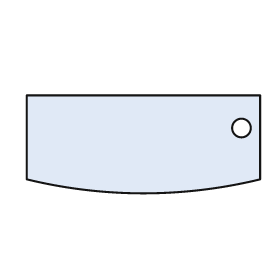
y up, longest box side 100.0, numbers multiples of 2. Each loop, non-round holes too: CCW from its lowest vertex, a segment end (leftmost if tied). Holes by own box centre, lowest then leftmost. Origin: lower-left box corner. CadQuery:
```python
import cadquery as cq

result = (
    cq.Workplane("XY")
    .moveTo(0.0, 6.0)
    .threePointArc((50.0, 0.0), (100.0, 6.0))
    .lineTo(100.0, 42.0)
    .lineTo(0.0, 42.0)
    .close()
    .moveTo(92.0, 28.0)
    .circle(4.0)
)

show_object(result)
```